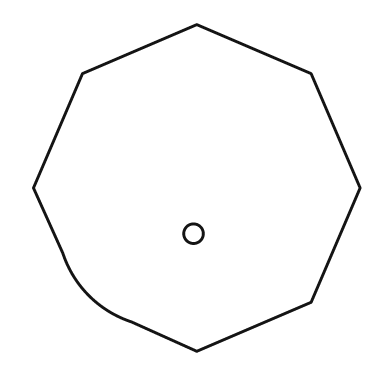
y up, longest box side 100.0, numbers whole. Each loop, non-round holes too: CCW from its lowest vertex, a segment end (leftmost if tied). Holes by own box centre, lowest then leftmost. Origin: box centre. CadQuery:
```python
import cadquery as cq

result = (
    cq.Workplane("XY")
    .moveTo(0.0, -50.0)
    .lineTo(35.0, -35.0)
    .lineTo(50.0, 0.0)
    .lineTo(35.0, 35.0)
    .lineTo(0.0, 50.0)
    .lineTo(-35.0, 35.0)
    .lineTo(-50.0, 0.0)
    .lineTo(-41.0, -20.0)
    .threePointArc((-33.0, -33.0), (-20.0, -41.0))
    .close()
    .moveTo(-1.0, -14.0)
    .circle(3.0)
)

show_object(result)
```